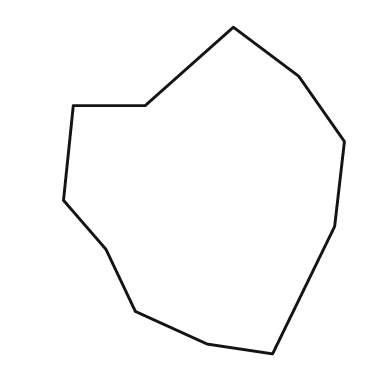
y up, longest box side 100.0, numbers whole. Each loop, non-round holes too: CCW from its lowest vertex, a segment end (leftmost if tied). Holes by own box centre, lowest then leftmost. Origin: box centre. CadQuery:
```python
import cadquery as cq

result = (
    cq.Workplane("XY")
    .moveTo(21.0, -50.0)
    .lineTo(40.0, -11.0)
    .lineTo(43.0, 15.0)
    .lineTo(29.0, 35.0)
    .lineTo(9.0, 50.0)
    .lineTo(-18.0, 26.0)
    .lineTo(-40.0, 26.0)
    .lineTo(-43.0, -3.0)
    .lineTo(-30.0, -18.0)
    .lineTo(-21.0, -37.0)
    .lineTo(1.0, -47.0)
    .close()
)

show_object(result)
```